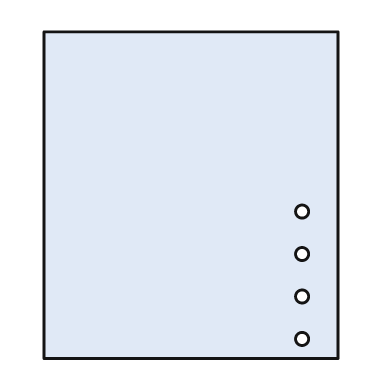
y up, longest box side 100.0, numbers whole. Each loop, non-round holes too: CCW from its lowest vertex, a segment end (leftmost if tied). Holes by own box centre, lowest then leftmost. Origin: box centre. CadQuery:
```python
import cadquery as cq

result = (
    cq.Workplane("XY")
    .moveTo(-45.0, -50.0)
    .lineTo(45.0, -50.0)
    .lineTo(45.0, 50.0)
    .lineTo(-45.0, 50.0)
    .close()
    .moveTo(34.0, -44.0)
    .circle(2.0)
    .moveTo(34.0, -31.0)
    .circle(2.0)
    .moveTo(34.0, -18.0)
    .circle(2.0)
    .moveTo(34.0, -5.0)
    .circle(2.0)
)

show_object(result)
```